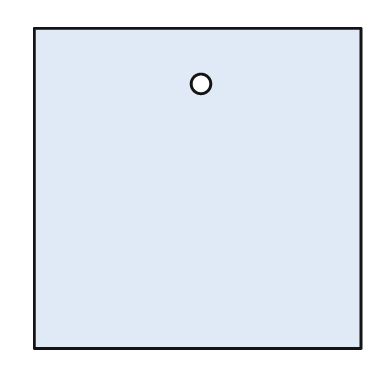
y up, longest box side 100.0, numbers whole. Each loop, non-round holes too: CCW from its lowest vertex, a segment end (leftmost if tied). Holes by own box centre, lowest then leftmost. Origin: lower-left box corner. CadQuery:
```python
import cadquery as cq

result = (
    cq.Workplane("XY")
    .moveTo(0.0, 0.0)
    .lineTo(100.0, 0.0)
    .lineTo(100.0, 98.0)
    .lineTo(0.0, 98.0)
    .close()
    .moveTo(51.0, 81.0)
    .circle(3.0)
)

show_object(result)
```